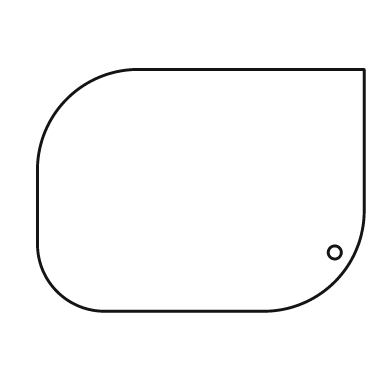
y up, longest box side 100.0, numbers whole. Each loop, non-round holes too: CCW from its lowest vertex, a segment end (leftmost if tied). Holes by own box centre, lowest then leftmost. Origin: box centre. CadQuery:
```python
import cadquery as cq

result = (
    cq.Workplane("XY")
    .moveTo(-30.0, -37.0)
    .lineTo(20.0, -37.0)
    .threePointArc((41.0, -28.0), (50.0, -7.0))
    .lineTo(50.0, 37.0)
    .lineTo(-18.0, 37.0)
    .threePointArc((-41.0, 28.0), (-50.0, 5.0))
    .lineTo(-50.0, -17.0)
    .threePointArc((-44.0, -31.0), (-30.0, -37.0))
    .close()
    .moveTo(41.0, -19.0)
    .circle(2.0)
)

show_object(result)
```